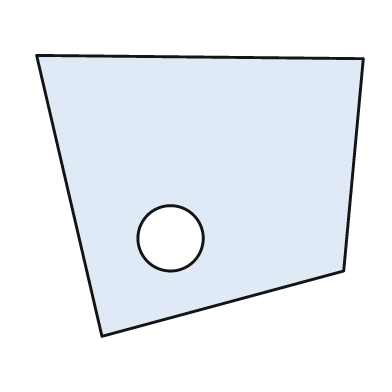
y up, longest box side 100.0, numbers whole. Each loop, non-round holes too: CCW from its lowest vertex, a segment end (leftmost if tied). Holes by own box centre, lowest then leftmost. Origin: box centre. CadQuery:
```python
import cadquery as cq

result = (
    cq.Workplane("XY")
    .moveTo(-30.0, -43.0)
    .lineTo(44.0, -23.0)
    .lineTo(50.0, 42.0)
    .lineTo(-50.0, 43.0)
    .close()
    .moveTo(-9.0, -13.0)
    .circle(10.0)
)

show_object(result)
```